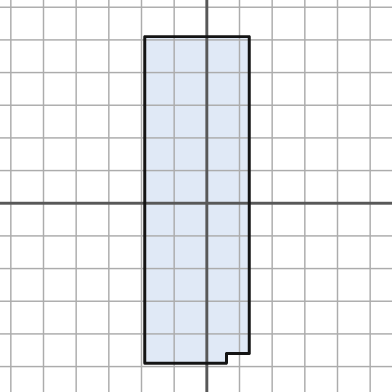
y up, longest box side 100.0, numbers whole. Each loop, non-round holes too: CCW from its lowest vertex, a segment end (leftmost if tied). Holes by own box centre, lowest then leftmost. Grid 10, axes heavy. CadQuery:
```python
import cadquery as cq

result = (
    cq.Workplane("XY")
    .moveTo(-19.0, -49.0)
    .lineTo(6.0, -49.0)
    .lineTo(6.0, -46.0)
    .lineTo(13.0, -46.0)
    .lineTo(13.0, 51.0)
    .lineTo(-19.0, 51.0)
    .close()
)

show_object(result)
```